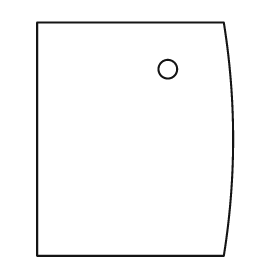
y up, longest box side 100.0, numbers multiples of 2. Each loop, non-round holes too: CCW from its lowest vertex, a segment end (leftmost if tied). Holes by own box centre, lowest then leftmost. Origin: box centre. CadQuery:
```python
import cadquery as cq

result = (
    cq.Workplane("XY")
    .moveTo(-42.0, -50.0)
    .lineTo(38.0, -50.0)
    .threePointArc((42.0, 0.0), (38.0, 50.0))
    .lineTo(-42.0, 50.0)
    .close()
    .moveTo(14.0, 30.0)
    .circle(4.0)
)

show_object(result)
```